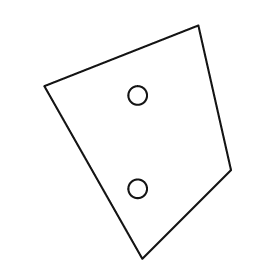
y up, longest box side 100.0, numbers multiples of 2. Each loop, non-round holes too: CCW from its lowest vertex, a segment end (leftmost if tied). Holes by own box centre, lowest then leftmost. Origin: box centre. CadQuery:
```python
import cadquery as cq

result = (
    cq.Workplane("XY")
    .moveTo(2.0, -50.0)
    .lineTo(40.0, -12.0)
    .lineTo(26.0, 50.0)
    .lineTo(-40.0, 24.0)
    .close()
    .moveTo(0.0, -20.0)
    .circle(4.0)
    .moveTo(0.0, 20.0)
    .circle(4.0)
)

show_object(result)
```